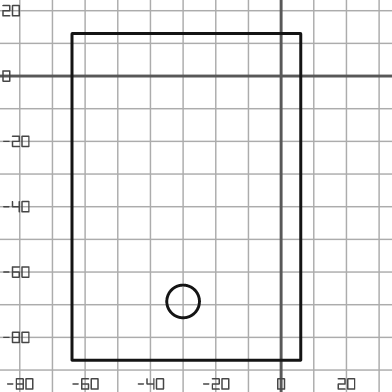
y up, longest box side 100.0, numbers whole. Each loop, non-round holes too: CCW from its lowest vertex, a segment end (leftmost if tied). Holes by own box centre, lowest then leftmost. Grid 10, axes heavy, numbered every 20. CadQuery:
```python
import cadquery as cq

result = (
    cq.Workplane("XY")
    .moveTo(-64.0, -87.0)
    .lineTo(6.0, -87.0)
    .lineTo(6.0, 13.0)
    .lineTo(-64.0, 13.0)
    .close()
    .moveTo(-30.0, -69.0)
    .circle(5.0)
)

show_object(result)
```